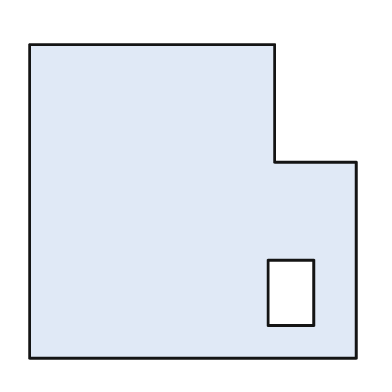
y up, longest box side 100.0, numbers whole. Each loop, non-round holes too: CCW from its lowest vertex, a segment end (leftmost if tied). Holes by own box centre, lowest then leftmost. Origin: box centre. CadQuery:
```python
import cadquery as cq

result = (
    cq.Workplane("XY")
    .moveTo(-50.0, -48.0)
    .lineTo(50.0, -48.0)
    .lineTo(50.0, 12.0)
    .lineTo(25.0, 12.0)
    .lineTo(25.0, 48.0)
    .lineTo(-50.0, 48.0)
    .close()
    .moveTo(23.0, -38.0)
    .lineTo(37.0, -38.0)
    .lineTo(37.0, -18.0)
    .lineTo(23.0, -18.0)
    .close()
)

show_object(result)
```